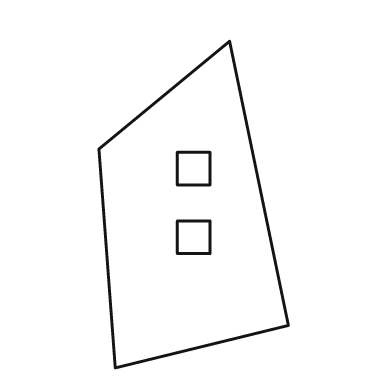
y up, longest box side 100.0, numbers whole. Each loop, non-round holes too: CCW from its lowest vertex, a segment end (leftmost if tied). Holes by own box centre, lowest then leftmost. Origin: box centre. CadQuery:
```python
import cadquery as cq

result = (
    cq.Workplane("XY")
    .moveTo(-24.0, -50.0)
    .lineTo(29.0, -37.0)
    .lineTo(11.0, 50.0)
    .lineTo(-29.0, 17.0)
    .close()
    .moveTo(-5.0, -15.0)
    .lineTo(5.0, -15.0)
    .lineTo(5.0, -5.0)
    .lineTo(-5.0, -5.0)
    .close()
    .moveTo(-5.0, 6.0)
    .lineTo(5.0, 6.0)
    .lineTo(5.0, 16.0)
    .lineTo(-5.0, 16.0)
    .close()
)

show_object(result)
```